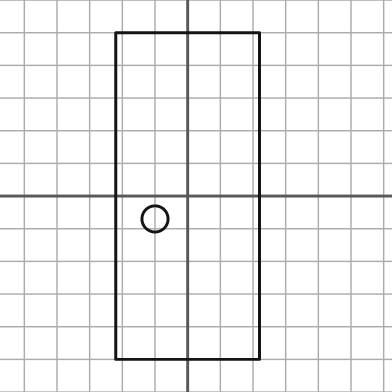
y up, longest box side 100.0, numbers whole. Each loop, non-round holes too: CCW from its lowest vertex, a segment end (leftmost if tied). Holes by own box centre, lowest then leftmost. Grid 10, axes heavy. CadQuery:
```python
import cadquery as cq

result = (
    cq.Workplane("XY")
    .moveTo(-22.0, -50.0)
    .lineTo(22.0, -50.0)
    .lineTo(22.0, 50.0)
    .lineTo(-22.0, 50.0)
    .close()
    .moveTo(-10.0, -7.0)
    .circle(4.0)
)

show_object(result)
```